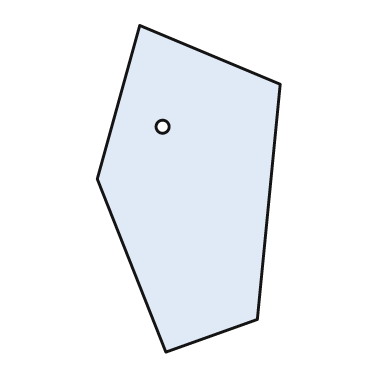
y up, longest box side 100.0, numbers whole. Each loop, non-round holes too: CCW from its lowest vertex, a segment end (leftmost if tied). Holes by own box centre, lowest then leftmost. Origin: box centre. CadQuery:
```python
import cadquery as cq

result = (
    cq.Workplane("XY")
    .moveTo(-7.0, -50.0)
    .lineTo(21.0, -40.0)
    .lineTo(28.0, 32.0)
    .lineTo(-15.0, 50.0)
    .lineTo(-28.0, 3.0)
    .close()
    .moveTo(-8.0, 19.0)
    .circle(2.0)
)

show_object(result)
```